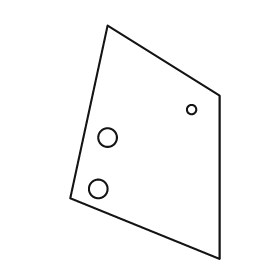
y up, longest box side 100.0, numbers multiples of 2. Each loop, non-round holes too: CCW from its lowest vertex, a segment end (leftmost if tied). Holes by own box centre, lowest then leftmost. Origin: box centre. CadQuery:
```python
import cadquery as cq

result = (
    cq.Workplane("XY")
    .moveTo(32.0, -50.0)
    .lineTo(32.0, 20.0)
    .lineTo(-16.0, 50.0)
    .lineTo(-32.0, -24.0)
    .close()
    .moveTo(-20.0, -20.0)
    .circle(4.0)
    .moveTo(-16.0, 2.0)
    .circle(4.0)
    .moveTo(20.0, 14.0)
    .circle(2.0)
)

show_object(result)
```